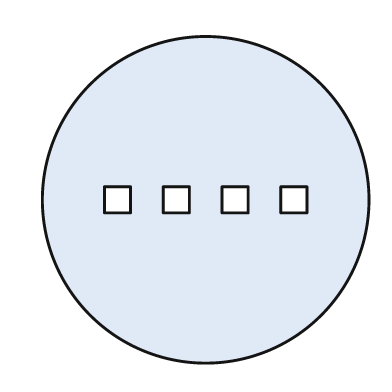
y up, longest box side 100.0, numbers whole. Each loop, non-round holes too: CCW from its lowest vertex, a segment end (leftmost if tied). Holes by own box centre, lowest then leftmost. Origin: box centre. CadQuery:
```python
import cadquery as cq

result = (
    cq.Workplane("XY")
    .moveTo(0.0, 0.0)
    .circle(50.0)
    .moveTo(-31.0, -4.0)
    .lineTo(-23.0, -4.0)
    .lineTo(-23.0, 4.0)
    .lineTo(-31.0, 4.0)
    .close()
    .moveTo(-13.0, -4.0)
    .lineTo(-5.0, -4.0)
    .lineTo(-5.0, 4.0)
    .lineTo(-13.0, 4.0)
    .close()
    .moveTo(5.0, -4.0)
    .lineTo(13.0, -4.0)
    .lineTo(13.0, 4.0)
    .lineTo(5.0, 4.0)
    .close()
    .moveTo(23.0, -4.0)
    .lineTo(31.0, -4.0)
    .lineTo(31.0, 4.0)
    .lineTo(23.0, 4.0)
    .close()
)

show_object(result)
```